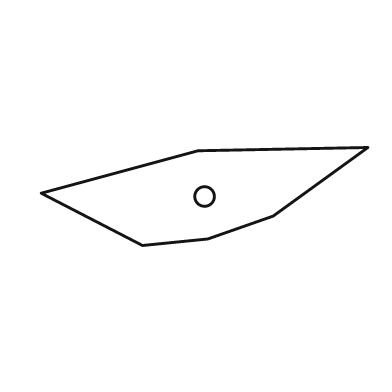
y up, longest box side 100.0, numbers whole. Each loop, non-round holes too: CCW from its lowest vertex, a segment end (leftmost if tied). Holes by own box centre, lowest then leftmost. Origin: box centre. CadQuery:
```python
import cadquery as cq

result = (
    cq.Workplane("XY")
    .moveTo(-19.0, -15.0)
    .lineTo(1.0, -13.0)
    .lineTo(21.0, -6.0)
    .lineTo(50.0, 15.0)
    .lineTo(-2.0, 14.0)
    .lineTo(-50.0, 1.0)
    .close()
    .moveTo(0.0, 0.0)
    .circle(3.0)
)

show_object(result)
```